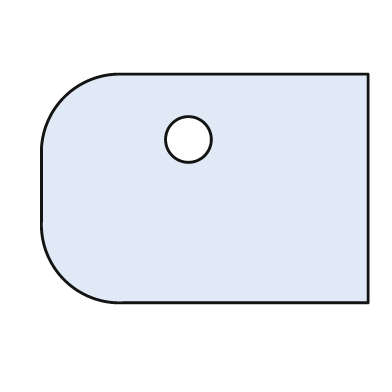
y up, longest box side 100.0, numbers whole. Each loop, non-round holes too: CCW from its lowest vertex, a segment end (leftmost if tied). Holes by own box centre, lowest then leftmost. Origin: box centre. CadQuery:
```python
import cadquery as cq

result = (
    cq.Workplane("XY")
    .moveTo(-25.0, -35.0)
    .lineTo(50.0, -35.0)
    .lineTo(50.0, 35.0)
    .lineTo(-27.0, 35.0)
    .threePointArc((-43.0, 28.0), (-50.0, 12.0))
    .lineTo(-50.0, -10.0)
    .threePointArc((-43.0, -28.0), (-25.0, -35.0))
    .close()
    .moveTo(-5.0, 15.0)
    .circle(7.0)
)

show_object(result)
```